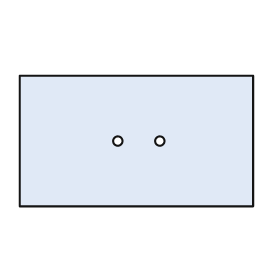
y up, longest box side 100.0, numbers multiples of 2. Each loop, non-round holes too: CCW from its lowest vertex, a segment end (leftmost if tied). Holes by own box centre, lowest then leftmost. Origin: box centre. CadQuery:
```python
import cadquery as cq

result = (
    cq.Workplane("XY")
    .moveTo(-50.0, -28.0)
    .lineTo(50.0, -28.0)
    .lineTo(50.0, 28.0)
    .lineTo(-50.0, 28.0)
    .close()
    .moveTo(-8.0, 0.0)
    .circle(2.0)
    .moveTo(10.0, 0.0)
    .circle(2.0)
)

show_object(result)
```